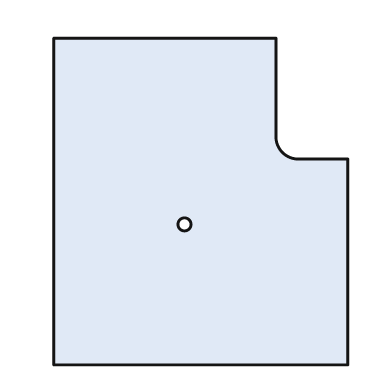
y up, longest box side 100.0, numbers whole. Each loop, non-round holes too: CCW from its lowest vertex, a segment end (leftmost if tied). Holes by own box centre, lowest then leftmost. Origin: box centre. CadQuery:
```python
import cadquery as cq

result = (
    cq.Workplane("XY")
    .moveTo(-45.0, -50.0)
    .lineTo(45.0, -50.0)
    .lineTo(45.0, 13.0)
    .lineTo(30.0, 13.0)
    .threePointArc((25.0, 15.0), (23.0, 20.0))
    .lineTo(23.0, 50.0)
    .lineTo(-45.0, 50.0)
    .close()
    .moveTo(-5.0, -7.0)
    .circle(2.0)
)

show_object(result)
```